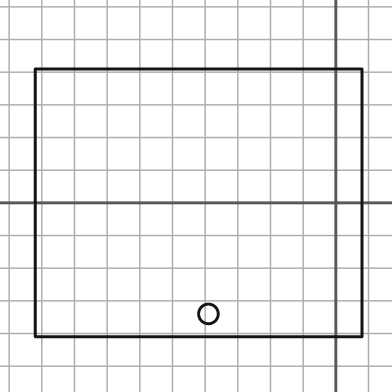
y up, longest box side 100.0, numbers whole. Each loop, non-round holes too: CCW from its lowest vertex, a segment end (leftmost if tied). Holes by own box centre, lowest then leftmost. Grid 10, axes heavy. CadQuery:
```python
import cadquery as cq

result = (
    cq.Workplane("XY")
    .moveTo(-92.0, -41.0)
    .lineTo(8.0, -41.0)
    .lineTo(8.0, 41.0)
    .lineTo(-92.0, 41.0)
    .close()
    .moveTo(-39.0, -34.0)
    .circle(3.0)
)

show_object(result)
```